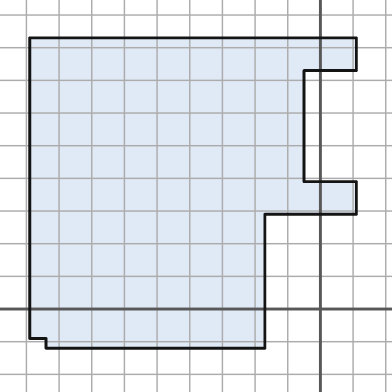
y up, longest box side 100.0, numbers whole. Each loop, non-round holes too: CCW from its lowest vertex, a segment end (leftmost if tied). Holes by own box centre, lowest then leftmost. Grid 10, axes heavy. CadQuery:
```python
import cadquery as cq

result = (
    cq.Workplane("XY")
    .moveTo(-84.0, -12.0)
    .lineTo(-17.0, -12.0)
    .lineTo(-17.0, 29.0)
    .lineTo(11.0, 29.0)
    .lineTo(11.0, 39.0)
    .lineTo(-5.0, 39.0)
    .lineTo(-5.0, 73.0)
    .lineTo(11.0, 73.0)
    .lineTo(11.0, 83.0)
    .lineTo(-89.0, 83.0)
    .lineTo(-89.0, -9.0)
    .lineTo(-84.0, -9.0)
    .close()
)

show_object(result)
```